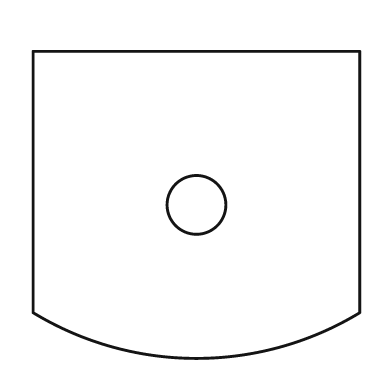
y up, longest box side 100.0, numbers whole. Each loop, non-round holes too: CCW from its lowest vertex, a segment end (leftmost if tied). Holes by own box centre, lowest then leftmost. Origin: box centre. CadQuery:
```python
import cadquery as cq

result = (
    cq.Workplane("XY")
    .moveTo(-50.0, -33.0)
    .threePointArc((0.0, -47.0), (50.0, -33.0))
    .lineTo(50.0, 47.0)
    .lineTo(-50.0, 47.0)
    .close()
    .moveTo(0.0, 0.0)
    .circle(9.0)
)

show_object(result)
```